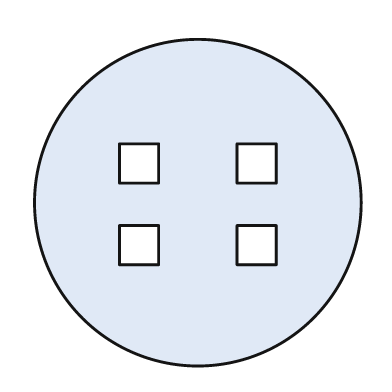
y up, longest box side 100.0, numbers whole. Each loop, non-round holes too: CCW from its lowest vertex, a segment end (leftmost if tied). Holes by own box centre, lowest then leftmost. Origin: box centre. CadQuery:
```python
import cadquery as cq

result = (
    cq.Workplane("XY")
    .moveTo(0.0, 0.0)
    .circle(50.0)
    .moveTo(-24.0, -19.0)
    .lineTo(-12.0, -19.0)
    .lineTo(-12.0, -7.0)
    .lineTo(-24.0, -7.0)
    .close()
    .moveTo(12.0, -19.0)
    .lineTo(24.0, -19.0)
    .lineTo(24.0, -7.0)
    .lineTo(12.0, -7.0)
    .close()
    .moveTo(-24.0, 6.0)
    .lineTo(-12.0, 6.0)
    .lineTo(-12.0, 18.0)
    .lineTo(-24.0, 18.0)
    .close()
    .moveTo(12.0, 6.0)
    .lineTo(24.0, 6.0)
    .lineTo(24.0, 18.0)
    .lineTo(12.0, 18.0)
    .close()
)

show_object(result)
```